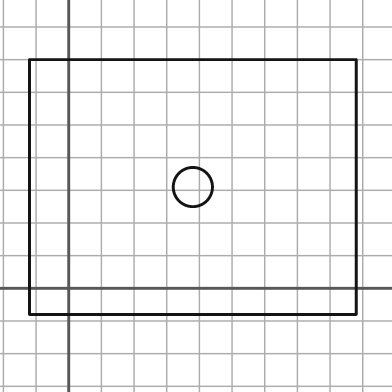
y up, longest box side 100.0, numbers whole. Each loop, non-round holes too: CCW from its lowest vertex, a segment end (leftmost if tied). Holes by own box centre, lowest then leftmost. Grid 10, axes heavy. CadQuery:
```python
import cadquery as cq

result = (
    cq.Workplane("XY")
    .moveTo(-12.0, -8.0)
    .lineTo(88.0, -8.0)
    .lineTo(88.0, 70.0)
    .lineTo(-12.0, 70.0)
    .close()
    .moveTo(38.0, 31.0)
    .circle(6.0)
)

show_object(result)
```